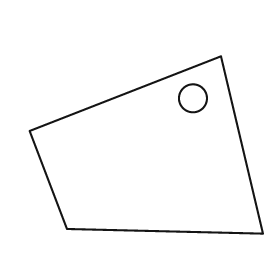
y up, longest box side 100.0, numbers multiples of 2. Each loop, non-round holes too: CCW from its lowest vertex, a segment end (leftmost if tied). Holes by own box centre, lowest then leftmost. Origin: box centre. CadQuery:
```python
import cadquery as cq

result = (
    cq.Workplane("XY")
    .moveTo(50.0, -38.0)
    .lineTo(32.0, 38.0)
    .lineTo(-50.0, 6.0)
    .lineTo(-34.0, -36.0)
    .close()
    .moveTo(20.0, 20.0)
    .circle(6.0)
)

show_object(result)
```